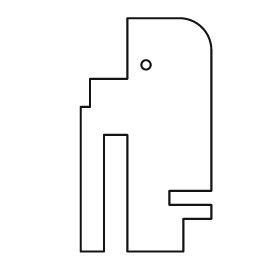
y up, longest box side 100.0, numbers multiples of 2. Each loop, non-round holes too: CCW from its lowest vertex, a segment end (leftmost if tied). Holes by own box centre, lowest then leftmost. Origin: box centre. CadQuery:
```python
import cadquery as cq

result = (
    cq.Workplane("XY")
    .moveTo(-28.0, -50.0)
    .lineTo(-18.0, -50.0)
    .lineTo(-18.0, 0.0)
    .lineTo(-8.0, 0.0)
    .lineTo(-8.0, -50.0)
    .lineTo(16.0, -50.0)
    .lineTo(16.0, -36.0)
    .lineTo(28.0, -36.0)
    .lineTo(28.0, -30.0)
    .lineTo(10.0, -30.0)
    .lineTo(10.0, -24.0)
    .lineTo(28.0, -24.0)
    .lineTo(28.0, 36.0)
    .threePointArc((24.0, 46.0), (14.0, 50.0))
    .lineTo(-8.0, 50.0)
    .lineTo(-8.0, 24.0)
    .lineTo(-24.0, 24.0)
    .lineTo(-24.0, 12.0)
    .lineTo(-28.0, 12.0)
    .close()
    .moveTo(0.0, 30.0)
    .circle(2.0)
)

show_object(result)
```